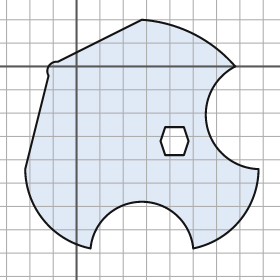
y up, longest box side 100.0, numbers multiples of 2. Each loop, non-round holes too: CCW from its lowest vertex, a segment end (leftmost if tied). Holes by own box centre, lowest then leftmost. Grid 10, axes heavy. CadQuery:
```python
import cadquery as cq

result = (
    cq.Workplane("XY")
    .moveTo(6.0, -78.0)
    .threePointArc((28.0, -58.0), (50.0, -78.0))
    .threePointArc((70.0, -66.0), (78.0, -44.0))
    .threePointArc((56.0, -26.0), (68.0, 0.0))
    .threePointArc((50.0, 14.0), (28.0, 20.0))
    .lineTo(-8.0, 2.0)
    .threePointArc((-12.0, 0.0), (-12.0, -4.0))
    .lineTo(-22.0, -44.0)
    .threePointArc((-14.0, -66.0), (6.0, -78.0))
    .close()
    .moveTo(38.0, -38.0)
    .lineTo(46.0, -38.0)
    .lineTo(48.0, -32.0)
    .lineTo(46.0, -26.0)
    .lineTo(38.0, -26.0)
    .lineTo(36.0, -32.0)
    .close()
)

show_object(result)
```